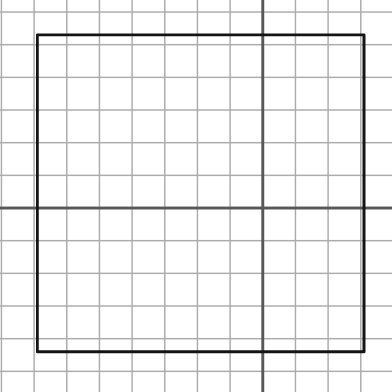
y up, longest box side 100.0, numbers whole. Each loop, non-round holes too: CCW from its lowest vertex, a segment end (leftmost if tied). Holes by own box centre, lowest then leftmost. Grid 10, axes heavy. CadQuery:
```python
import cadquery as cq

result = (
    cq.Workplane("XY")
    .moveTo(-69.0, -44.0)
    .lineTo(31.0, -44.0)
    .lineTo(31.0, 53.0)
    .lineTo(-69.0, 53.0)
    .close()
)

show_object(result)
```